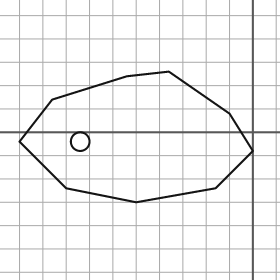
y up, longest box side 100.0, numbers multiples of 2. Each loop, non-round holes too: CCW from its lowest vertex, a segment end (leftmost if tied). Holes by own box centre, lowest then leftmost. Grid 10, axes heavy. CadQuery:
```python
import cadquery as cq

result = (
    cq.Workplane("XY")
    .moveTo(-50.0, -30.0)
    .lineTo(-16.0, -24.0)
    .lineTo(0.0, -8.0)
    .lineTo(-10.0, 8.0)
    .lineTo(-36.0, 26.0)
    .lineTo(-54.0, 24.0)
    .lineTo(-86.0, 14.0)
    .lineTo(-100.0, -4.0)
    .lineTo(-80.0, -24.0)
    .close()
    .moveTo(-74.0, -4.0)
    .circle(4.0)
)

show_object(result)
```